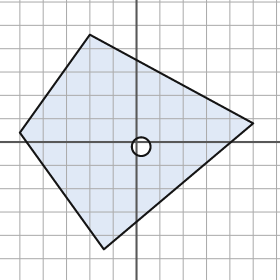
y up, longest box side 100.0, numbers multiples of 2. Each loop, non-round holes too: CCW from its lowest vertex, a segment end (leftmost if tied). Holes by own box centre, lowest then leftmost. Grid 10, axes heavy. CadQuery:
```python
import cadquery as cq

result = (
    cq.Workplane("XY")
    .moveTo(-14.0, -46.0)
    .lineTo(50.0, 8.0)
    .lineTo(-20.0, 46.0)
    .lineTo(-50.0, 4.0)
    .close()
    .moveTo(2.0, -2.0)
    .circle(4.0)
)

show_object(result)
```